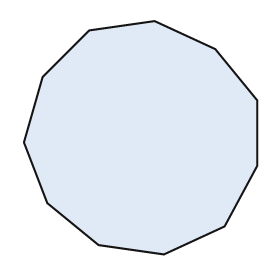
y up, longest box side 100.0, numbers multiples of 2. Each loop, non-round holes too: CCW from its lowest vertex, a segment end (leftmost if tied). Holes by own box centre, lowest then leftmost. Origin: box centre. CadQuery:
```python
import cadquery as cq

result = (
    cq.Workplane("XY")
    .moveTo(10.0, -50.0)
    .lineTo(36.0, -38.0)
    .lineTo(50.0, -12.0)
    .lineTo(50.0, 16.0)
    .lineTo(32.0, 38.0)
    .lineTo(6.0, 50.0)
    .lineTo(-22.0, 46.0)
    .lineTo(-42.0, 26.0)
    .lineTo(-50.0, -2.0)
    .lineTo(-40.0, -28.0)
    .lineTo(-18.0, -46.0)
    .close()
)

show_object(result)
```